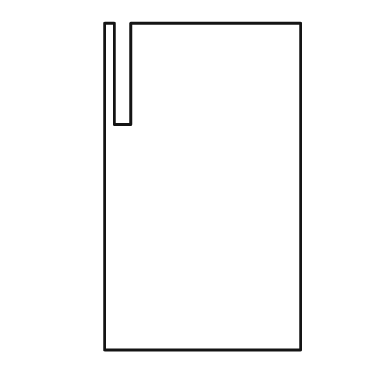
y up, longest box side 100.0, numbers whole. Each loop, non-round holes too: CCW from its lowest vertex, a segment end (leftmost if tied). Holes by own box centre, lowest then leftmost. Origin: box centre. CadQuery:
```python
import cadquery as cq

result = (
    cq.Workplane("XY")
    .moveTo(-30.0, -50.0)
    .lineTo(30.0, -50.0)
    .lineTo(30.0, 50.0)
    .lineTo(-22.0, 50.0)
    .lineTo(-22.0, 19.0)
    .lineTo(-27.0, 19.0)
    .lineTo(-27.0, 50.0)
    .lineTo(-30.0, 50.0)
    .close()
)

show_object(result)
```